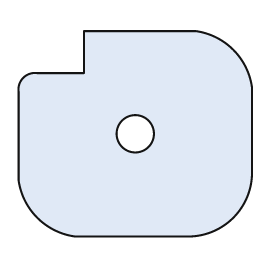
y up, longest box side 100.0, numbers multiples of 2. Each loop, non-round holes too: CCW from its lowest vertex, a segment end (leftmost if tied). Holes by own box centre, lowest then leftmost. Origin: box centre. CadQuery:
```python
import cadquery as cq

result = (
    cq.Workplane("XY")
    .moveTo(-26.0, -44.0)
    .lineTo(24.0, -44.0)
    .threePointArc((42.0, -36.0), (50.0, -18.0))
    .lineTo(50.0, 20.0)
    .threePointArc((42.0, 36.0), (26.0, 44.0))
    .lineTo(-22.0, 44.0)
    .lineTo(-22.0, 26.0)
    .lineTo(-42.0, 26.0)
    .threePointArc((-48.0, 24.0), (-50.0, 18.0))
    .lineTo(-50.0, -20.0)
    .threePointArc((-42.0, -36.0), (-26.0, -44.0))
    .close()
    .moveTo(0.0, 0.0)
    .circle(8.0)
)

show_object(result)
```